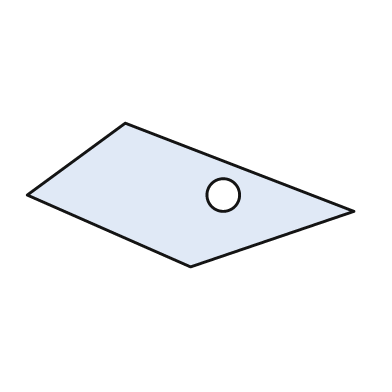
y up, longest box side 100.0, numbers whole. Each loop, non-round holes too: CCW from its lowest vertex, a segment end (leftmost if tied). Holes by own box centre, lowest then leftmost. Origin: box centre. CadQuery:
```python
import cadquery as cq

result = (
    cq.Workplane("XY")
    .moveTo(0.0, -22.0)
    .lineTo(50.0, -5.0)
    .lineTo(-20.0, 22.0)
    .lineTo(-50.0, 0.0)
    .close()
    .moveTo(10.0, 0.0)
    .circle(5.0)
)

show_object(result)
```